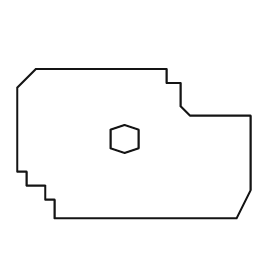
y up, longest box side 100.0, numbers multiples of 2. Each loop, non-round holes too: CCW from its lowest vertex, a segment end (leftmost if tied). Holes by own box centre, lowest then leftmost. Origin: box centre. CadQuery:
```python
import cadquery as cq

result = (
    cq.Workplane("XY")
    .moveTo(-34.0, -32.0)
    .lineTo(44.0, -32.0)
    .lineTo(50.0, -20.0)
    .lineTo(50.0, 12.0)
    .lineTo(24.0, 12.0)
    .lineTo(20.0, 16.0)
    .lineTo(20.0, 26.0)
    .lineTo(14.0, 26.0)
    .lineTo(14.0, 32.0)
    .lineTo(-42.0, 32.0)
    .lineTo(-50.0, 24.0)
    .lineTo(-50.0, -12.0)
    .lineTo(-46.0, -12.0)
    .lineTo(-46.0, -18.0)
    .lineTo(-38.0, -18.0)
    .lineTo(-38.0, -24.0)
    .lineTo(-34.0, -24.0)
    .close()
    .moveTo(-4.0, -4.0)
    .lineTo(2.0, -2.0)
    .lineTo(2.0, 6.0)
    .lineTo(-4.0, 8.0)
    .lineTo(-10.0, 6.0)
    .lineTo(-10.0, -2.0)
    .close()
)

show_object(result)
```